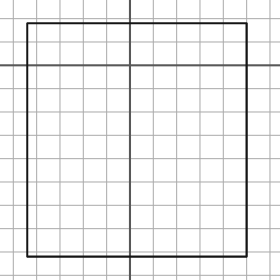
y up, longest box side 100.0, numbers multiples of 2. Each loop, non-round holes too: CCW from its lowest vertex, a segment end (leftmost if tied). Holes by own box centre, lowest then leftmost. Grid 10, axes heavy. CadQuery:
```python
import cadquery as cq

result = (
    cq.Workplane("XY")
    .moveTo(-44.0, -82.0)
    .lineTo(50.0, -82.0)
    .lineTo(50.0, 18.0)
    .lineTo(-44.0, 18.0)
    .close()
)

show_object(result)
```